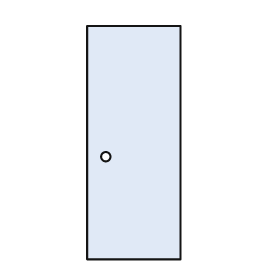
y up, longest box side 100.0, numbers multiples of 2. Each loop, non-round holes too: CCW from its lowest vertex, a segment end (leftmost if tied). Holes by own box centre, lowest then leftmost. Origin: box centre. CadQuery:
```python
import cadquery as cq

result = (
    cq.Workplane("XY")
    .moveTo(-20.0, -50.0)
    .lineTo(20.0, -50.0)
    .lineTo(20.0, 50.0)
    .lineTo(-20.0, 50.0)
    .close()
    .moveTo(-12.0, -6.0)
    .circle(2.0)
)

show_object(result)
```